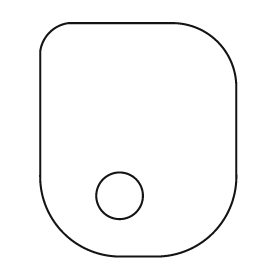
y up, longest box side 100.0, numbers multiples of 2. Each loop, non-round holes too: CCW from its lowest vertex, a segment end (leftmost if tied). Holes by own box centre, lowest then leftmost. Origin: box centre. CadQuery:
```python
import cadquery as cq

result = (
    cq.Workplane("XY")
    .moveTo(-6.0, -50.0)
    .lineTo(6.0, -50.0)
    .threePointArc((32.0, -40.0), (42.0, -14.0))
    .lineTo(42.0, 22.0)
    .threePointArc((34.0, 42.0), (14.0, 50.0))
    .lineTo(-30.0, 50.0)
    .threePointArc((-38.0, 46.0), (-42.0, 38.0))
    .lineTo(-42.0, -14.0)
    .threePointArc((-32.0, -40.0), (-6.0, -50.0))
    .close()
    .moveTo(-8.0, -24.0)
    .circle(10.0)
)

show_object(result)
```